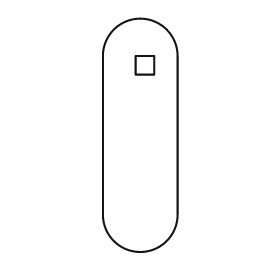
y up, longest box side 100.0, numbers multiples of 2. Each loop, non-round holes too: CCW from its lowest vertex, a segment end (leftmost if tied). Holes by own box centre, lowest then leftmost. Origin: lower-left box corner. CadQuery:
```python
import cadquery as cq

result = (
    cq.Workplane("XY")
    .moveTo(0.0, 16.0)
    .threePointArc((16.0, 0.0), (32.0, 16.0))
    .lineTo(32.0, 84.0)
    .threePointArc((16.0, 100.0), (0.0, 84.0))
    .close()
    .moveTo(14.0, 76.0)
    .lineTo(22.0, 76.0)
    .lineTo(22.0, 84.0)
    .lineTo(14.0, 84.0)
    .close()
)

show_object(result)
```